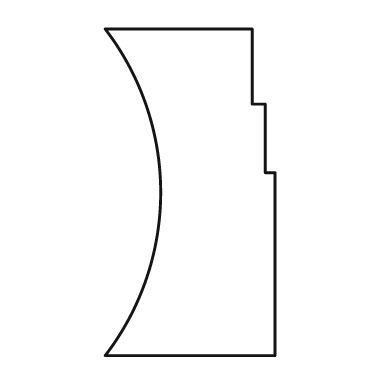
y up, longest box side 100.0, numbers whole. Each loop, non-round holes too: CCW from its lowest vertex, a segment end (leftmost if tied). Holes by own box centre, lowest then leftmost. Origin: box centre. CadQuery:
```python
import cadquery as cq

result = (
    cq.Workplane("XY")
    .moveTo(-26.0, -50.0)
    .lineTo(26.0, -50.0)
    .lineTo(26.0, 6.0)
    .lineTo(23.0, 6.0)
    .lineTo(23.0, 27.0)
    .lineTo(19.0, 27.0)
    .lineTo(19.0, 50.0)
    .lineTo(-26.0, 50.0)
    .threePointArc((-9.0, 0.0), (-26.0, -50.0))
    .close()
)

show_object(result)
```